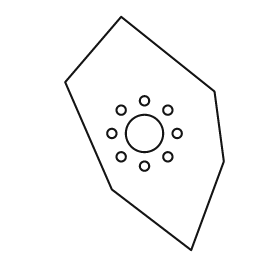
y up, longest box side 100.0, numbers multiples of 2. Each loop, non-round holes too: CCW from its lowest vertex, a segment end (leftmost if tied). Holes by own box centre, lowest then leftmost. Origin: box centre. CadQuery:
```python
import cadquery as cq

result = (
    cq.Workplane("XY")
    .moveTo(20.0, -50.0)
    .lineTo(34.0, -12.0)
    .lineTo(30.0, 18.0)
    .lineTo(-10.0, 50.0)
    .lineTo(-34.0, 22.0)
    .lineTo(-14.0, -24.0)
    .close()
    .moveTo(0.0, -14.0)
    .circle(2.0)
    .moveTo(-10.0, -10.0)
    .circle(2.0)
    .moveTo(10.0, -10.0)
    .circle(2.0)
    .moveTo(-14.0, 0.0)
    .circle(2.0)
    .moveTo(0.0, 0.0)
    .circle(8.0)
    .moveTo(14.0, 0.0)
    .circle(2.0)
    .moveTo(-10.0, 10.0)
    .circle(2.0)
    .moveTo(10.0, 10.0)
    .circle(2.0)
    .moveTo(0.0, 14.0)
    .circle(2.0)
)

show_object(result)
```